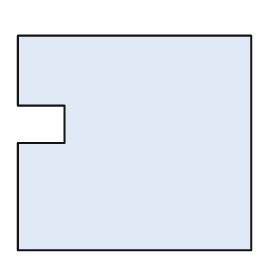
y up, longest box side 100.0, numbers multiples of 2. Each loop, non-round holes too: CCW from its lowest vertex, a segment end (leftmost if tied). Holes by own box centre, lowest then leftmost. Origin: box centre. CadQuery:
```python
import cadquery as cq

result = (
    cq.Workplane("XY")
    .moveTo(-50.0, -46.0)
    .lineTo(50.0, -46.0)
    .lineTo(50.0, 46.0)
    .lineTo(-50.0, 46.0)
    .lineTo(-50.0, 16.0)
    .lineTo(-30.0, 16.0)
    .lineTo(-30.0, 0.0)
    .lineTo(-50.0, 0.0)
    .close()
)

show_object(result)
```